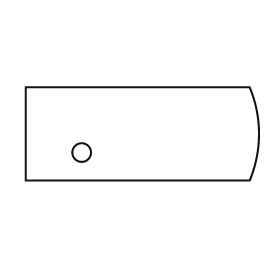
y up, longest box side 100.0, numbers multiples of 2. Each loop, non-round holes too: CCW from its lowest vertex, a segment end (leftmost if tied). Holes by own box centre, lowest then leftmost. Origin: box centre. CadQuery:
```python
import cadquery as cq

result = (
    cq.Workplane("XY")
    .moveTo(-50.0, -20.0)
    .lineTo(46.0, -20.0)
    .threePointArc((50.0, 0.0), (46.0, 20.0))
    .lineTo(-50.0, 20.0)
    .close()
    .moveTo(-26.0, -8.0)
    .circle(4.0)
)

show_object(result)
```